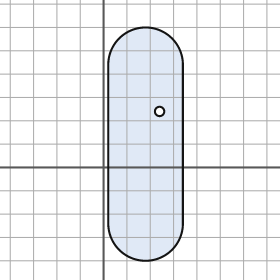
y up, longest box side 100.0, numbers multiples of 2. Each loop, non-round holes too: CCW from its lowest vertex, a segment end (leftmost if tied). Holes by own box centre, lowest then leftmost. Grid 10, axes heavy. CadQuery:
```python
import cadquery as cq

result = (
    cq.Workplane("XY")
    .moveTo(2.0, -24.0)
    .threePointArc((18.0, -40.0), (34.0, -24.0))
    .lineTo(34.0, 44.0)
    .threePointArc((18.0, 60.0), (2.0, 44.0))
    .close()
    .moveTo(24.0, 24.0)
    .circle(2.0)
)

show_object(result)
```